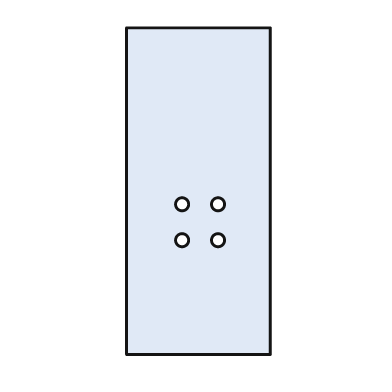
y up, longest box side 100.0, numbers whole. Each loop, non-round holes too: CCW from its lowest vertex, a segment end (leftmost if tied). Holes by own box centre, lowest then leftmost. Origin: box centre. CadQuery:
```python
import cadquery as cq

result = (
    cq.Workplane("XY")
    .moveTo(-22.0, -50.0)
    .lineTo(22.0, -50.0)
    .lineTo(22.0, 50.0)
    .lineTo(-22.0, 50.0)
    .close()
    .moveTo(-5.0, -15.0)
    .circle(2.0)
    .moveTo(6.0, -15.0)
    .circle(2.0)
    .moveTo(-5.0, -4.0)
    .circle(2.0)
    .moveTo(6.0, -4.0)
    .circle(2.0)
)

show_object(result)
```